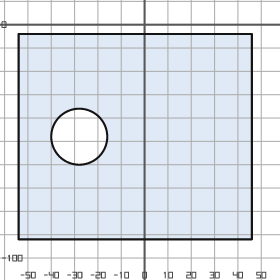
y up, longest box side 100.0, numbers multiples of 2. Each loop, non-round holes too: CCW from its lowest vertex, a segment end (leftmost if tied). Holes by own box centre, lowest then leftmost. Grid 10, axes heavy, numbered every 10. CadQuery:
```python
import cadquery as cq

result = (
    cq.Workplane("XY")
    .moveTo(-54.0, -92.0)
    .lineTo(46.0, -92.0)
    .lineTo(46.0, -4.0)
    .lineTo(-54.0, -4.0)
    .close()
    .moveTo(-28.0, -48.0)
    .circle(12.0)
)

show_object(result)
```